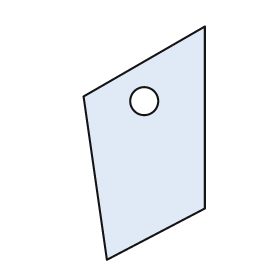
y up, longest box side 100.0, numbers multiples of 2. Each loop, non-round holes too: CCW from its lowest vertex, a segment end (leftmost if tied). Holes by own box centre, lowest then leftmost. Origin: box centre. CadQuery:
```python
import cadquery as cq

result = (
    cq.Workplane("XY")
    .moveTo(-16.0, -50.0)
    .lineTo(26.0, -28.0)
    .lineTo(26.0, 50.0)
    .lineTo(-26.0, 20.0)
    .close()
    .moveTo(0.0, 18.0)
    .circle(6.0)
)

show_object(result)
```